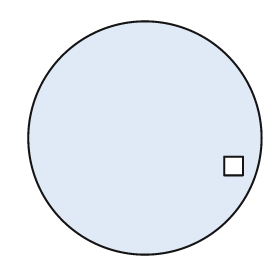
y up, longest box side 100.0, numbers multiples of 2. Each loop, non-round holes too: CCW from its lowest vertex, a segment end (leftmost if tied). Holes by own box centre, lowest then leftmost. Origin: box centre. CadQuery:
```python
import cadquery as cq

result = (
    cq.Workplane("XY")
    .moveTo(0.0, 0.0)
    .circle(50.0)
    .moveTo(34.0, -16.0)
    .lineTo(42.0, -16.0)
    .lineTo(42.0, -8.0)
    .lineTo(34.0, -8.0)
    .close()
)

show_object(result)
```